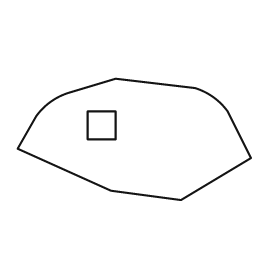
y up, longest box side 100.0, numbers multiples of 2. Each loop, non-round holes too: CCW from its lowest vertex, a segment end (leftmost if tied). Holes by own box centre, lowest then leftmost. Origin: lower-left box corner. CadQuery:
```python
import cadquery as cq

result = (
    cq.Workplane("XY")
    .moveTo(70.0, 0.0)
    .lineTo(100.0, 18.0)
    .lineTo(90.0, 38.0)
    .threePointArc((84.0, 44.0), (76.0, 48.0))
    .lineTo(42.0, 52.0)
    .lineTo(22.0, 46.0)
    .threePointArc((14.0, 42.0), (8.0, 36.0))
    .lineTo(0.0, 22.0)
    .lineTo(40.0, 4.0)
    .close()
    .moveTo(30.0, 26.0)
    .lineTo(42.0, 26.0)
    .lineTo(42.0, 38.0)
    .lineTo(30.0, 38.0)
    .close()
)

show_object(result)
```